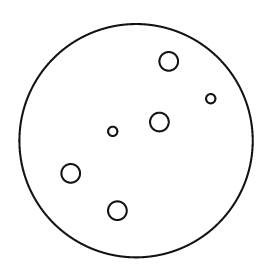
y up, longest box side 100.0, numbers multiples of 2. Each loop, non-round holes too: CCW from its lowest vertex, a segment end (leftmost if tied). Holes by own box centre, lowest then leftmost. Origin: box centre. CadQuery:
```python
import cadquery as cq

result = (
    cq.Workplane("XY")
    .moveTo(0.0, 0.0)
    .circle(50.0)
    .moveTo(-8.0, -30.0)
    .circle(4.0)
    .moveTo(-28.0, -14.0)
    .circle(4.0)
    .moveTo(-10.0, 4.0)
    .circle(2.0)
    .moveTo(10.0, 8.0)
    .circle(4.0)
    .moveTo(32.0, 18.0)
    .circle(2.0)
    .moveTo(14.0, 34.0)
    .circle(4.0)
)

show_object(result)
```